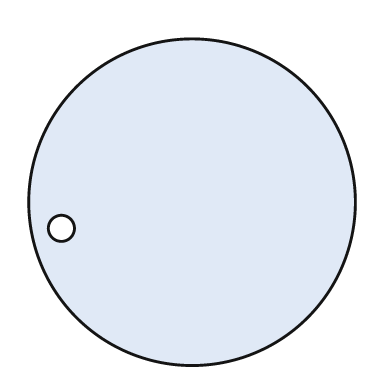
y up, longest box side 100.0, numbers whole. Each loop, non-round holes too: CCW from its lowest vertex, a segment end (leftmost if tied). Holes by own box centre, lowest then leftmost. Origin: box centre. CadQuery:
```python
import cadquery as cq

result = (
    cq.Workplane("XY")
    .moveTo(0.0, 0.0)
    .circle(50.0)
    .moveTo(-40.0, -8.0)
    .circle(4.0)
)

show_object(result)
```